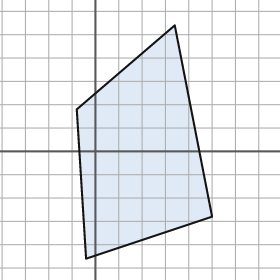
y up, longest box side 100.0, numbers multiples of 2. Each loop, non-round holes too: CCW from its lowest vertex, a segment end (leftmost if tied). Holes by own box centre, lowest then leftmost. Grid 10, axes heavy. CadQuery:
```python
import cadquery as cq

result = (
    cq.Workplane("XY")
    .moveTo(-4.0, -46.0)
    .lineTo(50.0, -28.0)
    .lineTo(34.0, 54.0)
    .lineTo(-8.0, 18.0)
    .close()
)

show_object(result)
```